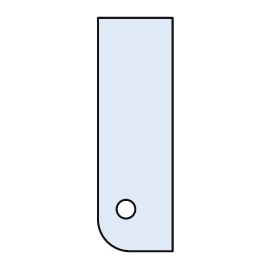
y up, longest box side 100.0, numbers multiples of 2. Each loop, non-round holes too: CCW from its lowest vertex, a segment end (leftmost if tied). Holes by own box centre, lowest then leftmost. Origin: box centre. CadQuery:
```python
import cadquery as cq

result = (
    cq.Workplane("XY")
    .moveTo(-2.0, -50.0)
    .lineTo(16.0, -50.0)
    .lineTo(16.0, 50.0)
    .lineTo(-16.0, 50.0)
    .lineTo(-16.0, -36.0)
    .threePointArc((-12.0, -46.0), (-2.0, -50.0))
    .close()
    .moveTo(-4.0, -32.0)
    .circle(4.0)
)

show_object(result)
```